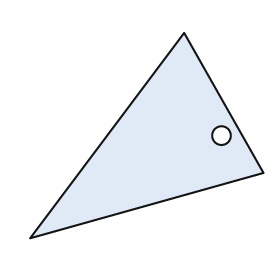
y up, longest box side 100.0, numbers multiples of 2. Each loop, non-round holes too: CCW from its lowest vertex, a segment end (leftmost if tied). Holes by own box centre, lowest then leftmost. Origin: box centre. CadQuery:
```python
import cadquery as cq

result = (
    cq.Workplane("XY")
    .moveTo(-50.0, -44.0)
    .lineTo(50.0, -16.0)
    .lineTo(16.0, 44.0)
    .close()
    .moveTo(32.0, 0.0)
    .circle(4.0)
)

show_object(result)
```